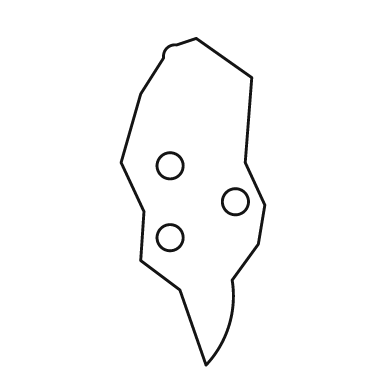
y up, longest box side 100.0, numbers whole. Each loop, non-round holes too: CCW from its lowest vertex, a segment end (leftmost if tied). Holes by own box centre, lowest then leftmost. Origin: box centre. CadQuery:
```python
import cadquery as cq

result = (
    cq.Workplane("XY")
    .moveTo(4.0, -50.0)
    .threePointArc((11.0, -38.0), (12.0, -24.0))
    .lineTo(20.0, -13.0)
    .lineTo(22.0, -1.0)
    .lineTo(16.0, 12.0)
    .lineTo(18.0, 38.0)
    .lineTo(1.0, 50.0)
    .lineTo(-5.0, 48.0)
    .threePointArc((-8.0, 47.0), (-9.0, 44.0))
    .lineTo(-16.0, 33.0)
    .lineTo(-22.0, 12.0)
    .lineTo(-15.0, -3.0)
    .lineTo(-16.0, -18.0)
    .lineTo(-4.0, -27.0)
    .close()
    .moveTo(-7.0, -11.0)
    .circle(4.0)
    .moveTo(13.0, 0.0)
    .circle(4.0)
    .moveTo(-7.0, 11.0)
    .circle(4.0)
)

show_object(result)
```